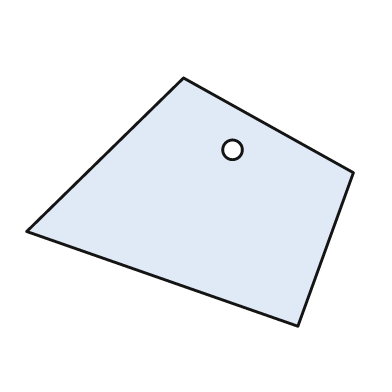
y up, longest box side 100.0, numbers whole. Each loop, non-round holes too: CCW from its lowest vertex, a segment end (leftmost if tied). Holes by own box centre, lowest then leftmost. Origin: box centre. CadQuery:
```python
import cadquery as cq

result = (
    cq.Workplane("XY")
    .moveTo(33.0, -38.0)
    .lineTo(50.0, 9.0)
    .lineTo(-2.0, 38.0)
    .lineTo(-50.0, -9.0)
    .close()
    .moveTo(13.0, 16.0)
    .circle(3.0)
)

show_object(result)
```